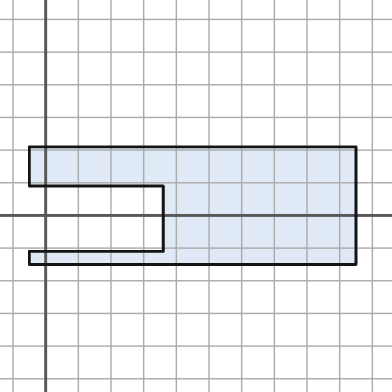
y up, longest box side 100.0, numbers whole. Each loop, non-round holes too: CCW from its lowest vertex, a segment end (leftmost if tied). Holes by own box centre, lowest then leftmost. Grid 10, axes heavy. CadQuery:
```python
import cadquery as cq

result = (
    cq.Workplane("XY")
    .moveTo(-5.0, -15.0)
    .lineTo(95.0, -15.0)
    .lineTo(95.0, 21.0)
    .lineTo(-5.0, 21.0)
    .lineTo(-5.0, 9.0)
    .lineTo(36.0, 9.0)
    .lineTo(36.0, -11.0)
    .lineTo(-5.0, -11.0)
    .close()
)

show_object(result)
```